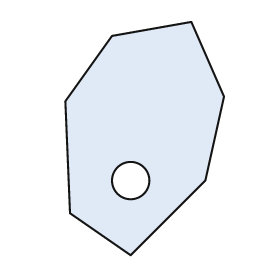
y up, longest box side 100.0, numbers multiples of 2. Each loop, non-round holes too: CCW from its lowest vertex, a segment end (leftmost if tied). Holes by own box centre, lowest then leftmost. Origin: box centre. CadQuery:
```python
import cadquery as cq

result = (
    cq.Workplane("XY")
    .moveTo(-6.0, -50.0)
    .lineTo(26.0, -18.0)
    .lineTo(34.0, 18.0)
    .lineTo(20.0, 50.0)
    .lineTo(-14.0, 44.0)
    .lineTo(-34.0, 16.0)
    .lineTo(-32.0, -32.0)
    .close()
    .moveTo(-6.0, -18.0)
    .circle(8.0)
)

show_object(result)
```